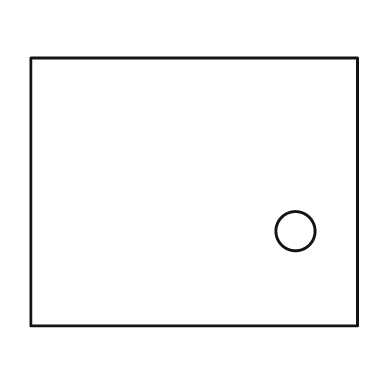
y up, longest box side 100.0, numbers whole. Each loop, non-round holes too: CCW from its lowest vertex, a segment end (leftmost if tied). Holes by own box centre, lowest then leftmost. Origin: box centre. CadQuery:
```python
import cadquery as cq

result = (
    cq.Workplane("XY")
    .moveTo(-50.0, -41.0)
    .lineTo(50.0, -41.0)
    .lineTo(50.0, 41.0)
    .lineTo(-50.0, 41.0)
    .close()
    .moveTo(31.0, -12.0)
    .circle(6.0)
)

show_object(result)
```